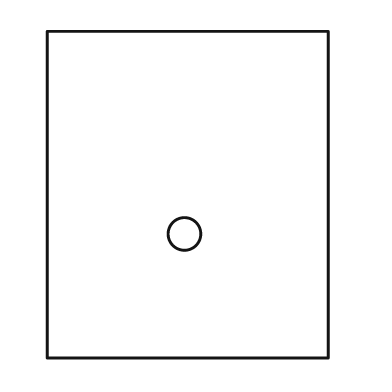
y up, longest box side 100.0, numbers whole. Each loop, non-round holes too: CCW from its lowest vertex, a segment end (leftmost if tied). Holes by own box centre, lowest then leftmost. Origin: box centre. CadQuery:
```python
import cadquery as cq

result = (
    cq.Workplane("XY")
    .moveTo(-43.0, -50.0)
    .lineTo(43.0, -50.0)
    .lineTo(43.0, 50.0)
    .lineTo(-43.0, 50.0)
    .close()
    .moveTo(-1.0, -12.0)
    .circle(5.0)
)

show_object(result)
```